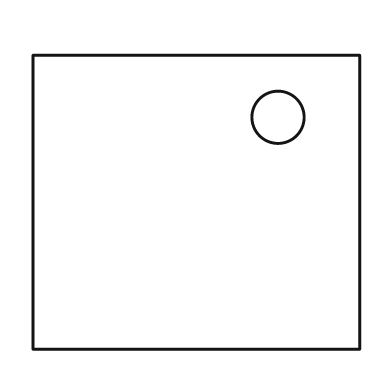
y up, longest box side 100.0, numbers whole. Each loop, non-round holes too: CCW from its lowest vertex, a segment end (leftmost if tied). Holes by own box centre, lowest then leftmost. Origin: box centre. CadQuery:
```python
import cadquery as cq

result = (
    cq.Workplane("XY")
    .moveTo(-50.0, -45.0)
    .lineTo(50.0, -45.0)
    .lineTo(50.0, 45.0)
    .lineTo(-50.0, 45.0)
    .close()
    .moveTo(25.0, 26.0)
    .circle(8.0)
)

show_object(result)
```